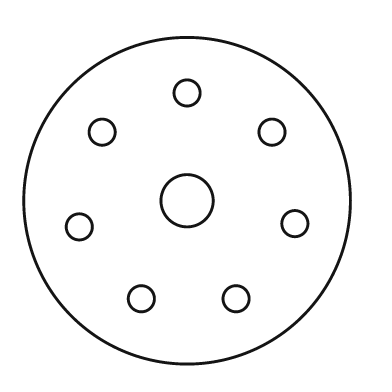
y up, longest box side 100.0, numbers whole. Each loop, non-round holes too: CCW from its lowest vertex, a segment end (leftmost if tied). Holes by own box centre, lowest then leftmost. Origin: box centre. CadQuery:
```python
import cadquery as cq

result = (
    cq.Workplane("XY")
    .moveTo(0.0, 0.0)
    .circle(50.0)
    .moveTo(-14.0, -30.0)
    .circle(4.0)
    .moveTo(15.0, -30.0)
    .circle(4.0)
    .moveTo(-33.0, -8.0)
    .circle(4.0)
    .moveTo(33.0, -7.0)
    .circle(4.0)
    .moveTo(0.0, 0.0)
    .circle(8.0)
    .moveTo(-26.0, 21.0)
    .circle(4.0)
    .moveTo(26.0, 21.0)
    .circle(4.0)
    .moveTo(0.0, 33.0)
    .circle(4.0)
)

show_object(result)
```